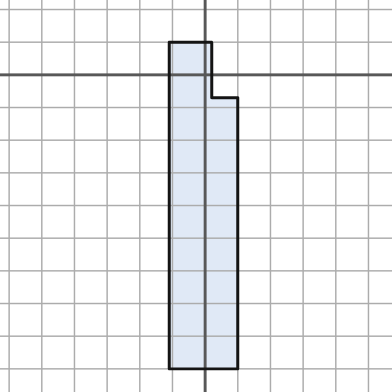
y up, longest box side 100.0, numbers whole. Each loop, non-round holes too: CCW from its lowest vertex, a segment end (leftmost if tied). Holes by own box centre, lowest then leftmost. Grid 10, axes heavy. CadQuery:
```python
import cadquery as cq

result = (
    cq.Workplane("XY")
    .moveTo(-11.0, -90.0)
    .lineTo(10.0, -90.0)
    .lineTo(10.0, -7.0)
    .lineTo(2.0, -7.0)
    .lineTo(2.0, 10.0)
    .lineTo(-11.0, 10.0)
    .close()
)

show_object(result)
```